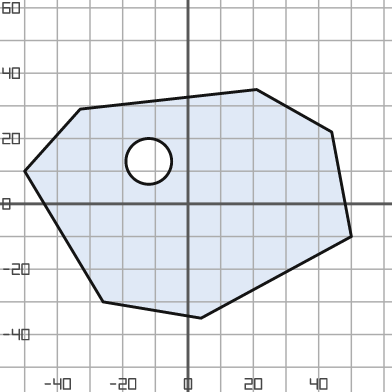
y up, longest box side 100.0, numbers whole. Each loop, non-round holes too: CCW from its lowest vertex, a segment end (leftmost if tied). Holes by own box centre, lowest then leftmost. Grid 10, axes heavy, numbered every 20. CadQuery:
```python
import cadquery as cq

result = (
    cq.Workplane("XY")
    .moveTo(4.0, -35.0)
    .lineTo(50.0, -10.0)
    .lineTo(44.0, 22.0)
    .lineTo(21.0, 35.0)
    .lineTo(-33.0, 29.0)
    .lineTo(-50.0, 10.0)
    .lineTo(-26.0, -30.0)
    .close()
    .moveTo(-12.0, 13.0)
    .circle(7.0)
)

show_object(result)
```